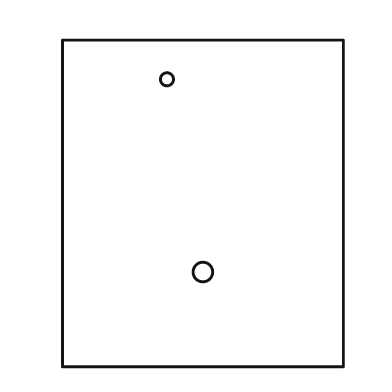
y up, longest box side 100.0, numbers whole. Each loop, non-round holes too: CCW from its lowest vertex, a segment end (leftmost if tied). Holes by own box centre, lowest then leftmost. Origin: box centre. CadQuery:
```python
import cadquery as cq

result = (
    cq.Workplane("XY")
    .moveTo(-43.0, -50.0)
    .lineTo(43.0, -50.0)
    .lineTo(43.0, 50.0)
    .lineTo(-43.0, 50.0)
    .close()
    .moveTo(0.0, -21.0)
    .circle(3.0)
    .moveTo(-11.0, 38.0)
    .circle(2.0)
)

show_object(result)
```